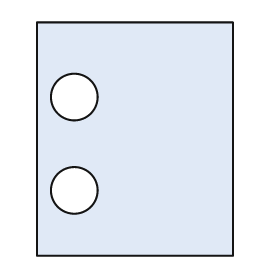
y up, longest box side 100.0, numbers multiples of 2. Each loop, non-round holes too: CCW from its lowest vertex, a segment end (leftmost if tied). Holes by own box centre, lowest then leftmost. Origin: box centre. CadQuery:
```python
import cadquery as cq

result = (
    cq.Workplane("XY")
    .moveTo(-42.0, -50.0)
    .lineTo(42.0, -50.0)
    .lineTo(42.0, 50.0)
    .lineTo(-42.0, 50.0)
    .close()
    .moveTo(-26.0, -22.0)
    .circle(10.0)
    .moveTo(-26.0, 18.0)
    .circle(10.0)
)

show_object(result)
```